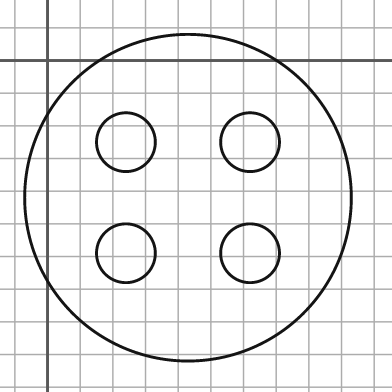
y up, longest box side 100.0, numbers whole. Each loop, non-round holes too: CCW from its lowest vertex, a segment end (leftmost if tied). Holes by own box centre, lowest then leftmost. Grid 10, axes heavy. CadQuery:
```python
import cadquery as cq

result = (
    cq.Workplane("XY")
    .moveTo(43.0, -42.0)
    .circle(50.0)
    .moveTo(24.0, -59.0)
    .circle(9.0)
    .moveTo(62.0, -59.0)
    .circle(9.0)
    .moveTo(24.0, -25.0)
    .circle(9.0)
    .moveTo(62.0, -25.0)
    .circle(9.0)
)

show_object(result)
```